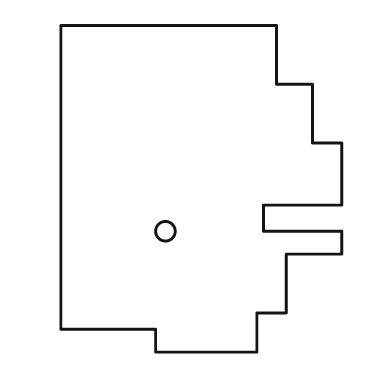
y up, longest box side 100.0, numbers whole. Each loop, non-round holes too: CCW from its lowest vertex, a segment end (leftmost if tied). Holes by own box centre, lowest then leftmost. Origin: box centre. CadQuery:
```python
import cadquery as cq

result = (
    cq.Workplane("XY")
    .moveTo(-14.0, -50.0)
    .lineTo(17.0, -50.0)
    .lineTo(17.0, -38.0)
    .lineTo(26.0, -38.0)
    .lineTo(26.0, -20.0)
    .lineTo(43.0, -20.0)
    .lineTo(43.0, -13.0)
    .lineTo(19.0, -13.0)
    .lineTo(19.0, -5.0)
    .lineTo(43.0, -5.0)
    .lineTo(43.0, 14.0)
    .lineTo(34.0, 14.0)
    .lineTo(34.0, 32.0)
    .lineTo(23.0, 32.0)
    .lineTo(23.0, 50.0)
    .lineTo(-43.0, 50.0)
    .lineTo(-43.0, -43.0)
    .lineTo(-14.0, -43.0)
    .close()
    .moveTo(-11.0, -13.0)
    .circle(3.0)
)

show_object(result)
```